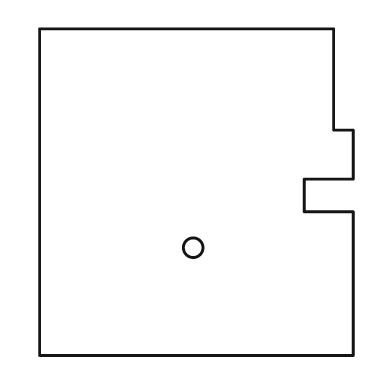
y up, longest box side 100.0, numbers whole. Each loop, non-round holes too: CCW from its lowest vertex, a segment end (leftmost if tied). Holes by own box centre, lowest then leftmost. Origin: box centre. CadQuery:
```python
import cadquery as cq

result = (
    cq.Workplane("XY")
    .moveTo(-48.0, -50.0)
    .lineTo(48.0, -50.0)
    .lineTo(48.0, -6.0)
    .lineTo(33.0, -6.0)
    .lineTo(33.0, 4.0)
    .lineTo(48.0, 4.0)
    .lineTo(48.0, 19.0)
    .lineTo(42.0, 19.0)
    .lineTo(42.0, 50.0)
    .lineTo(-48.0, 50.0)
    .close()
    .moveTo(-1.0, -17.0)
    .circle(3.0)
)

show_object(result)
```